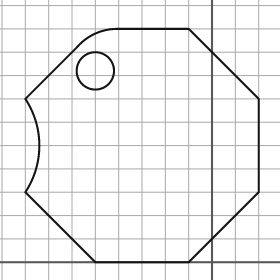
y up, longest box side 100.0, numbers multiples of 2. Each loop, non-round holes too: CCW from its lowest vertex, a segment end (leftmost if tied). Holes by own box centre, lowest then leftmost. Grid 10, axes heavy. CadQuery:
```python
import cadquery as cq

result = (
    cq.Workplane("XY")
    .moveTo(-50.0, 0.0)
    .lineTo(-10.0, 0.0)
    .lineTo(20.0, 30.0)
    .lineTo(20.0, 70.0)
    .lineTo(-10.0, 100.0)
    .lineTo(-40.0, 100.0)
    .threePointArc((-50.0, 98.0), (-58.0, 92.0))
    .lineTo(-80.0, 70.0)
    .threePointArc((-74.0, 50.0), (-80.0, 30.0))
    .close()
    .moveTo(-50.0, 82.0)
    .circle(8.0)
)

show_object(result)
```